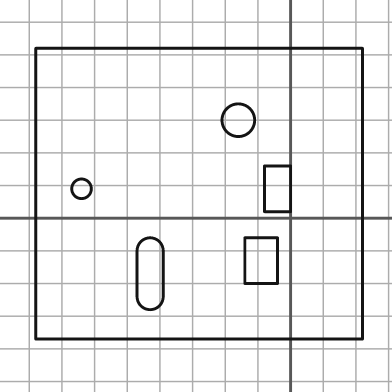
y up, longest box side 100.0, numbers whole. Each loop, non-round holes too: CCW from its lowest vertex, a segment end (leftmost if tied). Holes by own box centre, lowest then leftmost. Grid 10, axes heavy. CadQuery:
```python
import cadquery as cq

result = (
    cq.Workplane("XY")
    .moveTo(-78.0, -37.0)
    .lineTo(22.0, -37.0)
    .lineTo(22.0, 52.0)
    .lineTo(-78.0, 52.0)
    .close()
    .moveTo(-47.0, -24.0)
    .threePointArc((-43.0, -28.0), (-39.0, -24.0))
    .lineTo(-39.0, -10.0)
    .threePointArc((-43.0, -6.0), (-47.0, -10.0))
    .close()
    .moveTo(-14.0, -20.0)
    .lineTo(-4.0, -20.0)
    .lineTo(-4.0, -6.0)
    .lineTo(-14.0, -6.0)
    .close()
    .moveTo(-64.0, 9.0)
    .circle(3.0)
    .moveTo(-8.0, 2.0)
    .lineTo(0.0, 2.0)
    .lineTo(0.0, 16.0)
    .lineTo(-8.0, 16.0)
    .close()
    .moveTo(-16.0, 30.0)
    .circle(5.0)
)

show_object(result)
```